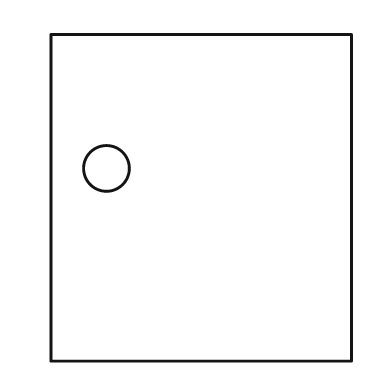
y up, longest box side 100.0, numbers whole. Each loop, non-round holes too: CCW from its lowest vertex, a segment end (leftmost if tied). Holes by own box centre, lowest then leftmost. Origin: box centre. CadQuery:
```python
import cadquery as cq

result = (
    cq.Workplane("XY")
    .moveTo(-46.0, -50.0)
    .lineTo(46.0, -50.0)
    .lineTo(46.0, 50.0)
    .lineTo(-46.0, 50.0)
    .close()
    .moveTo(-29.0, 9.0)
    .circle(7.0)
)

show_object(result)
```